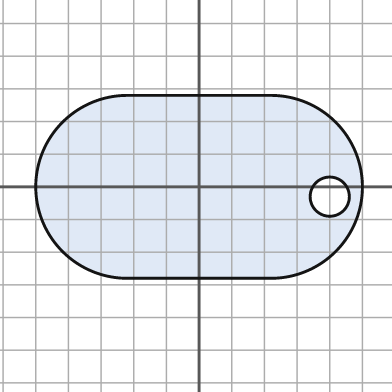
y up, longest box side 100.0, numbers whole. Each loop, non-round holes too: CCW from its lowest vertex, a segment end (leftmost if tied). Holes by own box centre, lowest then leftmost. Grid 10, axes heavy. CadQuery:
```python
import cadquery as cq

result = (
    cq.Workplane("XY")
    .moveTo(-22.0, -28.0)
    .lineTo(22.0, -28.0)
    .threePointArc((50.0, 0.0), (22.0, 28.0))
    .lineTo(-22.0, 28.0)
    .threePointArc((-50.0, 0.0), (-22.0, -28.0))
    .close()
    .moveTo(40.0, -3.0)
    .circle(6.0)
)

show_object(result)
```